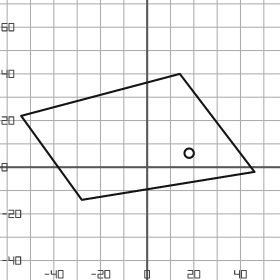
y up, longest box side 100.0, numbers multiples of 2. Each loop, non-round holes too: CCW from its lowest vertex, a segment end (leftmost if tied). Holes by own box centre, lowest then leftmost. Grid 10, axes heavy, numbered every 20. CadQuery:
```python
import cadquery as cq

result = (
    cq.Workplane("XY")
    .moveTo(-28.0, -14.0)
    .lineTo(46.0, -2.0)
    .lineTo(14.0, 40.0)
    .lineTo(-54.0, 22.0)
    .close()
    .moveTo(18.0, 6.0)
    .circle(2.0)
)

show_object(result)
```